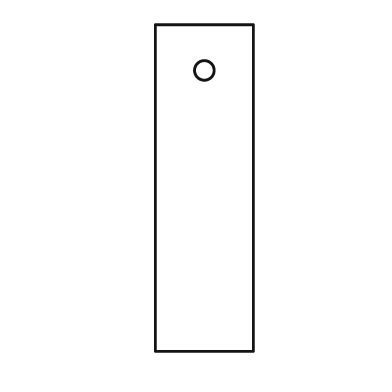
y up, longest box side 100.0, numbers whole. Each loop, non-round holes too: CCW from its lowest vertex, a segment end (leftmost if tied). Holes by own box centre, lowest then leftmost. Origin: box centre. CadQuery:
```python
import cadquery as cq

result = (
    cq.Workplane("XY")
    .moveTo(-15.0, -50.0)
    .lineTo(15.0, -50.0)
    .lineTo(15.0, 50.0)
    .lineTo(-15.0, 50.0)
    .close()
    .moveTo(0.0, 36.0)
    .circle(3.0)
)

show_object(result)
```